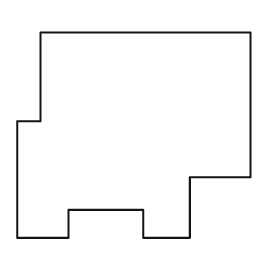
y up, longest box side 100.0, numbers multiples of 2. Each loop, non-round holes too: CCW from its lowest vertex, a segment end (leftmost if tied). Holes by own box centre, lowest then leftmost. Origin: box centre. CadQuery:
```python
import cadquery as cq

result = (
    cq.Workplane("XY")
    .moveTo(-50.0, -44.0)
    .lineTo(-28.0, -44.0)
    .lineTo(-28.0, -32.0)
    .lineTo(4.0, -32.0)
    .lineTo(4.0, -44.0)
    .lineTo(24.0, -44.0)
    .lineTo(24.0, -18.0)
    .lineTo(50.0, -18.0)
    .lineTo(50.0, 44.0)
    .lineTo(-40.0, 44.0)
    .lineTo(-40.0, 6.0)
    .lineTo(-50.0, 6.0)
    .close()
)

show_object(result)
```